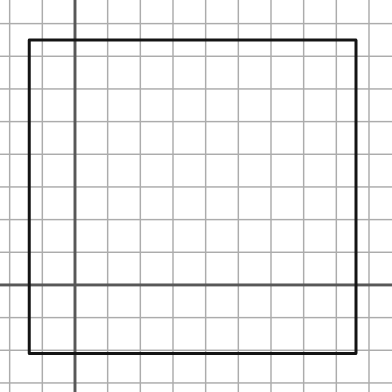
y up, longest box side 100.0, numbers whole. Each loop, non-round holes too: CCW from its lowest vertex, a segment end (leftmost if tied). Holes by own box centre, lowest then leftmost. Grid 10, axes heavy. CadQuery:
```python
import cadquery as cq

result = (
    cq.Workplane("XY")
    .moveTo(-14.0, -21.0)
    .lineTo(86.0, -21.0)
    .lineTo(86.0, 75.0)
    .lineTo(-14.0, 75.0)
    .close()
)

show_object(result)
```